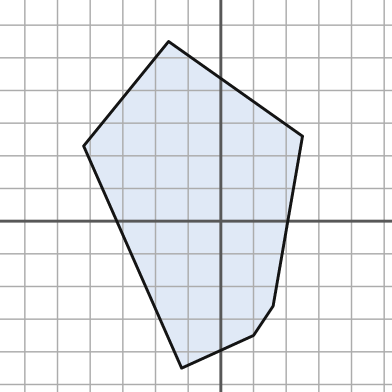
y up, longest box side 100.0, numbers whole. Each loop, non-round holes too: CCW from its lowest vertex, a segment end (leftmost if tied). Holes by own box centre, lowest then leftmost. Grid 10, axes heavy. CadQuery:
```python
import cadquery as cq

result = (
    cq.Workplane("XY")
    .moveTo(-12.0, -45.0)
    .lineTo(10.0, -35.0)
    .lineTo(16.0, -26.0)
    .lineTo(25.0, 26.0)
    .lineTo(-16.0, 55.0)
    .lineTo(-42.0, 23.0)
    .close()
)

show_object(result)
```